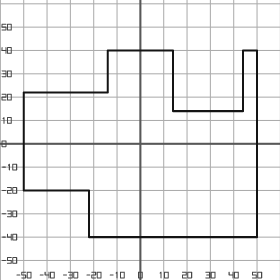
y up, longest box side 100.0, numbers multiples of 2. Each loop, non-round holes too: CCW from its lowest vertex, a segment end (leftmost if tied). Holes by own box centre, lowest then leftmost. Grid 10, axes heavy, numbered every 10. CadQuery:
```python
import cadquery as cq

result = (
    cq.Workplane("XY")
    .moveTo(-22.0, -40.0)
    .lineTo(50.0, -40.0)
    .lineTo(50.0, 40.0)
    .lineTo(44.0, 40.0)
    .lineTo(44.0, 14.0)
    .lineTo(14.0, 14.0)
    .lineTo(14.0, 40.0)
    .lineTo(-14.0, 40.0)
    .lineTo(-14.0, 22.0)
    .lineTo(-50.0, 22.0)
    .lineTo(-50.0, -20.0)
    .lineTo(-22.0, -20.0)
    .close()
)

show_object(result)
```